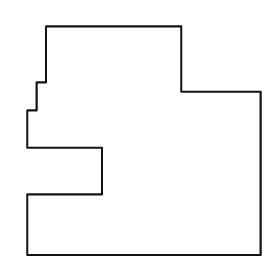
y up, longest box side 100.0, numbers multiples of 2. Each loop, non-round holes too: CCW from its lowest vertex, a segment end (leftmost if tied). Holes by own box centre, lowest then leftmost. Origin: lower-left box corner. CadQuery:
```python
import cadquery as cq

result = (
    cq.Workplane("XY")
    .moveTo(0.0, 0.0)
    .lineTo(100.0, 0.0)
    .lineTo(100.0, 70.0)
    .lineTo(66.0, 70.0)
    .lineTo(66.0, 98.0)
    .lineTo(8.0, 98.0)
    .lineTo(8.0, 74.0)
    .lineTo(4.0, 74.0)
    .lineTo(4.0, 62.0)
    .lineTo(0.0, 62.0)
    .lineTo(0.0, 46.0)
    .lineTo(32.0, 46.0)
    .lineTo(32.0, 26.0)
    .lineTo(0.0, 26.0)
    .close()
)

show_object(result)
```